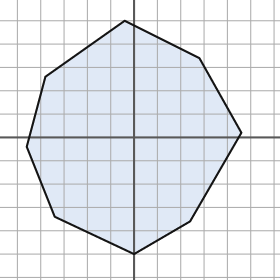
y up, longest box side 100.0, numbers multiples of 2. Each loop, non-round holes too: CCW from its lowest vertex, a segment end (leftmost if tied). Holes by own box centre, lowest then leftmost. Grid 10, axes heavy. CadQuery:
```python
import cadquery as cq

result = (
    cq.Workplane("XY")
    .moveTo(0.0, -50.0)
    .lineTo(24.0, -36.0)
    .lineTo(46.0, 2.0)
    .lineTo(28.0, 34.0)
    .lineTo(-4.0, 50.0)
    .lineTo(-38.0, 26.0)
    .lineTo(-46.0, -4.0)
    .lineTo(-34.0, -34.0)
    .close()
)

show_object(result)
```